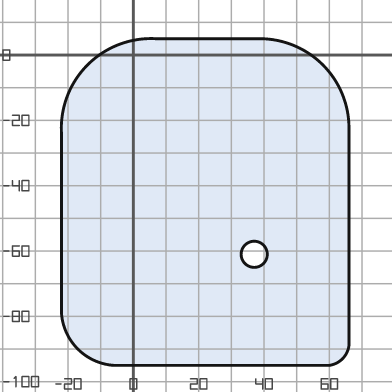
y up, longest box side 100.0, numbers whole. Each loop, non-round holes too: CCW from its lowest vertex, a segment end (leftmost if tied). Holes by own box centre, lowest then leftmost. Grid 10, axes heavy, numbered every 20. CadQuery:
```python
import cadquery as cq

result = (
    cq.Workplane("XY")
    .moveTo(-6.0, -95.0)
    .lineTo(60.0, -95.0)
    .threePointArc((64.0, -93.0), (66.0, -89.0))
    .lineTo(66.0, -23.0)
    .threePointArc((58.0, -3.0), (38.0, 5.0))
    .lineTo(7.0, 5.0)
    .threePointArc((-14.0, -3.0), (-22.0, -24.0))
    .lineTo(-22.0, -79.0)
    .threePointArc((-17.0, -90.0), (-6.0, -95.0))
    .close()
    .moveTo(37.0, -61.0)
    .circle(4.0)
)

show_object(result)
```